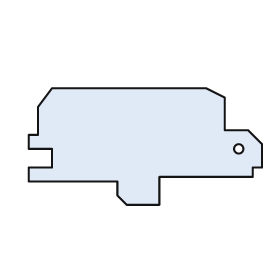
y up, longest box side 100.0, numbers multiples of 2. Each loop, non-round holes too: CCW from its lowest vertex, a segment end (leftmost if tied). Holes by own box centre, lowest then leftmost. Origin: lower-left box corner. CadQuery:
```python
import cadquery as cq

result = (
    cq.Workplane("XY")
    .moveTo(42.0, 0.0)
    .lineTo(56.0, 0.0)
    .lineTo(56.0, 12.0)
    .lineTo(96.0, 12.0)
    .lineTo(96.0, 16.0)
    .lineTo(100.0, 16.0)
    .lineTo(100.0, 26.0)
    .lineTo(94.0, 32.0)
    .lineTo(84.0, 32.0)
    .lineTo(84.0, 46.0)
    .lineTo(76.0, 50.0)
    .lineTo(10.0, 50.0)
    .lineTo(4.0, 42.0)
    .lineTo(4.0, 30.0)
    .lineTo(0.0, 30.0)
    .lineTo(0.0, 24.0)
    .lineTo(10.0, 24.0)
    .lineTo(10.0, 16.0)
    .lineTo(0.0, 16.0)
    .lineTo(0.0, 10.0)
    .lineTo(38.0, 10.0)
    .lineTo(38.0, 4.0)
    .close()
    .moveTo(90.0, 24.0)
    .circle(2.0)
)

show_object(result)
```